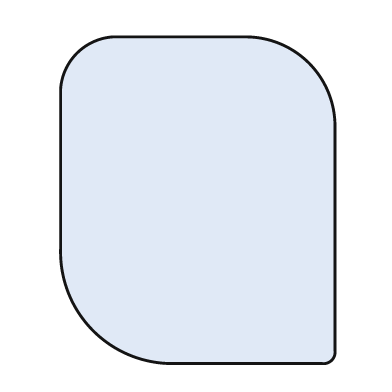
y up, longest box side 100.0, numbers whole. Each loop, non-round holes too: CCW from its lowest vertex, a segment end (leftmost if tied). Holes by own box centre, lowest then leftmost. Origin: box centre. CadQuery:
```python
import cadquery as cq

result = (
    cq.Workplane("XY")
    .moveTo(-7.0, -50.0)
    .lineTo(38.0, -50.0)
    .threePointArc((41.0, -49.0), (42.0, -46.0))
    .lineTo(42.0, 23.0)
    .threePointArc((34.0, 42.0), (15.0, 50.0))
    .lineTo(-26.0, 50.0)
    .threePointArc((-37.0, 45.0), (-42.0, 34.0))
    .lineTo(-42.0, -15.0)
    .threePointArc((-32.0, -40.0), (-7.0, -50.0))
    .close()
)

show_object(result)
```